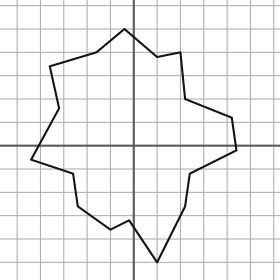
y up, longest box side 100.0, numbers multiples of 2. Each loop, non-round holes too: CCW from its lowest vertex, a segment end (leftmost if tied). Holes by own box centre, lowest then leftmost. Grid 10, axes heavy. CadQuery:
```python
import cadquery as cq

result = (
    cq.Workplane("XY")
    .moveTo(10.0, -50.0)
    .lineTo(22.0, -26.0)
    .lineTo(24.0, -12.0)
    .lineTo(44.0, -2.0)
    .lineTo(42.0, 12.0)
    .lineTo(22.0, 20.0)
    .lineTo(20.0, 40.0)
    .lineTo(10.0, 38.0)
    .lineTo(-4.0, 50.0)
    .lineTo(-16.0, 40.0)
    .lineTo(-36.0, 34.0)
    .lineTo(-32.0, 16.0)
    .lineTo(-44.0, -6.0)
    .lineTo(-26.0, -12.0)
    .lineTo(-24.0, -26.0)
    .lineTo(-10.0, -36.0)
    .lineTo(-2.0, -32.0)
    .close()
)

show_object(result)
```